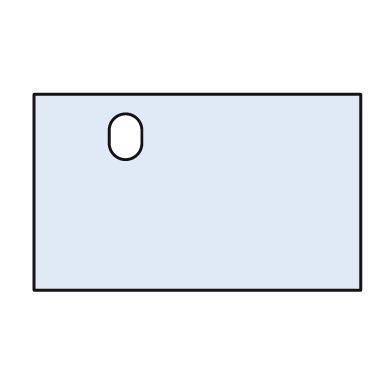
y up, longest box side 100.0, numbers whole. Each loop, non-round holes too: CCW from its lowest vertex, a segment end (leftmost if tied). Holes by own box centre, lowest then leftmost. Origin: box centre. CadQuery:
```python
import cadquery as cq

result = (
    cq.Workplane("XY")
    .moveTo(-50.0, -30.0)
    .lineTo(50.0, -30.0)
    .lineTo(50.0, 30.0)
    .lineTo(-50.0, 30.0)
    .close()
    .moveTo(-27.0, 15.0)
    .threePointArc((-22.0, 10.0), (-17.0, 15.0))
    .lineTo(-17.0, 19.0)
    .threePointArc((-22.0, 24.0), (-27.0, 19.0))
    .close()
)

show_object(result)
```